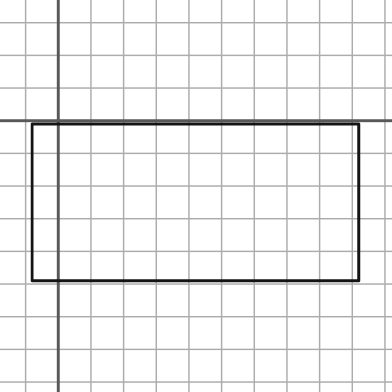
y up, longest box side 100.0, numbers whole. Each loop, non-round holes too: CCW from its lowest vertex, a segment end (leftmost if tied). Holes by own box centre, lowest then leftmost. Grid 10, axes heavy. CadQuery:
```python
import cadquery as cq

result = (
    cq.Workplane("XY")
    .moveTo(-8.0, -49.0)
    .lineTo(92.0, -49.0)
    .lineTo(92.0, -1.0)
    .lineTo(-8.0, -1.0)
    .close()
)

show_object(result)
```